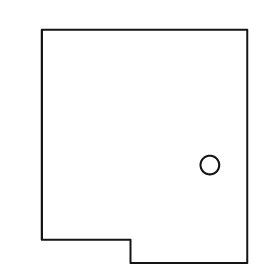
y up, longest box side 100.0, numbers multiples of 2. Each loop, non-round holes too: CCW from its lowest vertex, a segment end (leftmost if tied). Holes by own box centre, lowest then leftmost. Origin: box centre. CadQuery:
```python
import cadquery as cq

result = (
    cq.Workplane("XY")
    .moveTo(-6.0, -50.0)
    .lineTo(44.0, -50.0)
    .lineTo(44.0, 50.0)
    .lineTo(-44.0, 50.0)
    .lineTo(-44.0, -40.0)
    .lineTo(-6.0, -40.0)
    .close()
    .moveTo(28.0, -8.0)
    .circle(4.0)
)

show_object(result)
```